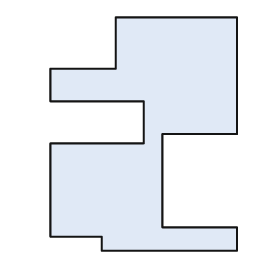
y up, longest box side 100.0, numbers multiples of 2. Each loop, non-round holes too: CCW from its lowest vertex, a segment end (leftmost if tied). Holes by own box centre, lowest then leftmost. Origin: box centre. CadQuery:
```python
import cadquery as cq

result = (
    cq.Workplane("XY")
    .moveTo(-18.0, -50.0)
    .lineTo(40.0, -50.0)
    .lineTo(40.0, -40.0)
    .lineTo(8.0, -40.0)
    .lineTo(8.0, 0.0)
    .lineTo(40.0, 0.0)
    .lineTo(40.0, 50.0)
    .lineTo(-12.0, 50.0)
    .lineTo(-12.0, 28.0)
    .lineTo(-40.0, 28.0)
    .lineTo(-40.0, 14.0)
    .lineTo(0.0, 14.0)
    .lineTo(0.0, -4.0)
    .lineTo(-40.0, -4.0)
    .lineTo(-40.0, -44.0)
    .lineTo(-18.0, -44.0)
    .close()
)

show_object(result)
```